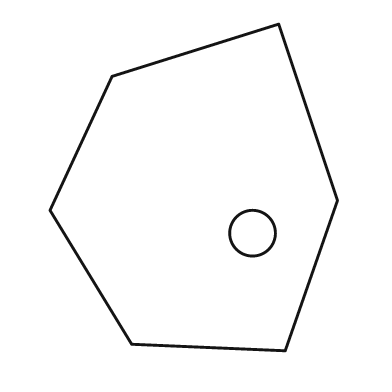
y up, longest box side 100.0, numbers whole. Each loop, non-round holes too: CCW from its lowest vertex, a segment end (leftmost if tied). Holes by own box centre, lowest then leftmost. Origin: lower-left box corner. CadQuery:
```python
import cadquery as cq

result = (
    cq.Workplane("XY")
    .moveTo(72.0, 0.0)
    .lineTo(88.0, 46.0)
    .lineTo(70.0, 100.0)
    .lineTo(19.0, 84.0)
    .lineTo(0.0, 43.0)
    .lineTo(25.0, 2.0)
    .close()
    .moveTo(62.0, 36.0)
    .circle(7.0)
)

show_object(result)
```